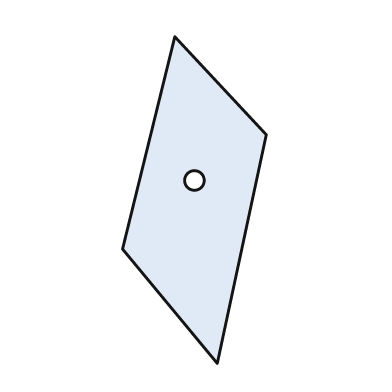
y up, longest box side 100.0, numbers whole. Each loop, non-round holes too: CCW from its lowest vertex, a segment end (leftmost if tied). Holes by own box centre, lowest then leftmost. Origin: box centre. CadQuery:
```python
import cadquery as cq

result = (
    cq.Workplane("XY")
    .moveTo(7.0, -50.0)
    .lineTo(22.0, 20.0)
    .lineTo(-6.0, 50.0)
    .lineTo(-22.0, -15.0)
    .close()
    .moveTo(0.0, 6.0)
    .circle(3.0)
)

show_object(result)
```